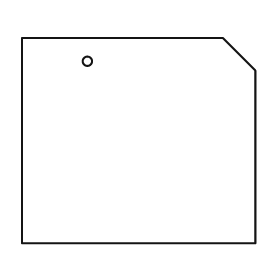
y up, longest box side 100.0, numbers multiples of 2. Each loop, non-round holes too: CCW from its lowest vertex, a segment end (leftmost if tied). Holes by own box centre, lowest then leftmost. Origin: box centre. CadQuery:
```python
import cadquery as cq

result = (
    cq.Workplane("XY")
    .moveTo(-50.0, -44.0)
    .lineTo(50.0, -44.0)
    .lineTo(50.0, 30.0)
    .lineTo(36.0, 44.0)
    .lineTo(-50.0, 44.0)
    .close()
    .moveTo(-22.0, 34.0)
    .circle(2.0)
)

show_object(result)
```